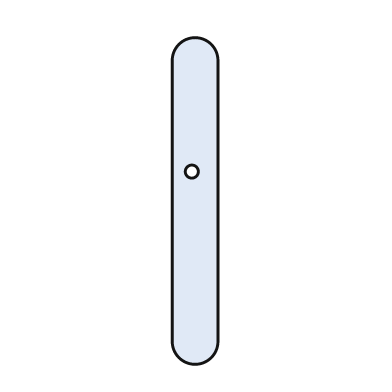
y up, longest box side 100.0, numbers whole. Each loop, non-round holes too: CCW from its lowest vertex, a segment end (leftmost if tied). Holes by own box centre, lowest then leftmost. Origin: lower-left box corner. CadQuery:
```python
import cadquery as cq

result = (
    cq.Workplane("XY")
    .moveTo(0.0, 7.0)
    .threePointArc((7.0, 0.0), (14.0, 7.0))
    .lineTo(14.0, 93.0)
    .threePointArc((7.0, 100.0), (0.0, 93.0))
    .close()
    .moveTo(6.0, 59.0)
    .circle(2.0)
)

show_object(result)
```